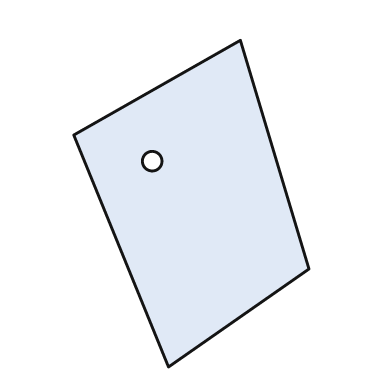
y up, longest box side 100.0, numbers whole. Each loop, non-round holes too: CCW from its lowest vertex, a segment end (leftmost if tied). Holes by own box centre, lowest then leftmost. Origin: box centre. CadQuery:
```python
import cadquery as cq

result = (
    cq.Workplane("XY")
    .moveTo(-7.0, -50.0)
    .lineTo(36.0, -20.0)
    .lineTo(15.0, 50.0)
    .lineTo(-36.0, 21.0)
    .close()
    .moveTo(-12.0, 13.0)
    .circle(3.0)
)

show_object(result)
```